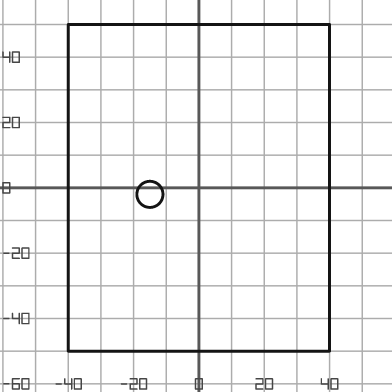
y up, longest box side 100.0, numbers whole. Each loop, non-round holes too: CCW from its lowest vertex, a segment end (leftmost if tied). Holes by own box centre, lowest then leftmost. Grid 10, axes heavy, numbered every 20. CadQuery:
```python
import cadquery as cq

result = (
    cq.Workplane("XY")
    .moveTo(-40.0, -50.0)
    .lineTo(40.0, -50.0)
    .lineTo(40.0, 50.0)
    .lineTo(-40.0, 50.0)
    .close()
    .moveTo(-15.0, -2.0)
    .circle(4.0)
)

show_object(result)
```